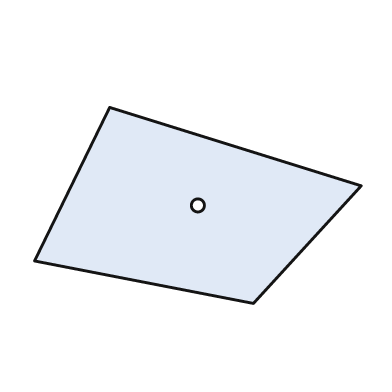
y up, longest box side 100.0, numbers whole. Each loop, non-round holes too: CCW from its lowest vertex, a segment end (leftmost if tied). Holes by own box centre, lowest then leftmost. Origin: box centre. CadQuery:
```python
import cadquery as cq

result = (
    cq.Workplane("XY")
    .moveTo(17.0, -30.0)
    .lineTo(50.0, 6.0)
    .lineTo(-27.0, 30.0)
    .lineTo(-50.0, -17.0)
    .close()
    .moveTo(0.0, 0.0)
    .circle(2.0)
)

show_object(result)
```